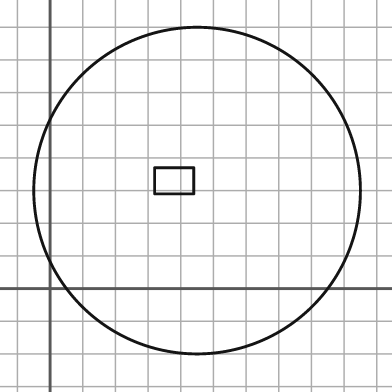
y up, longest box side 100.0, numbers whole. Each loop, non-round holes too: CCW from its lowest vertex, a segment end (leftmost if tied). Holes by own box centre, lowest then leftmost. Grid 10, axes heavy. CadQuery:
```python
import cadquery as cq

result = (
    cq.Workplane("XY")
    .moveTo(45.0, 30.0)
    .circle(50.0)
    .moveTo(32.0, 29.0)
    .lineTo(44.0, 29.0)
    .lineTo(44.0, 37.0)
    .lineTo(32.0, 37.0)
    .close()
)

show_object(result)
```